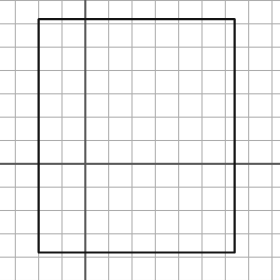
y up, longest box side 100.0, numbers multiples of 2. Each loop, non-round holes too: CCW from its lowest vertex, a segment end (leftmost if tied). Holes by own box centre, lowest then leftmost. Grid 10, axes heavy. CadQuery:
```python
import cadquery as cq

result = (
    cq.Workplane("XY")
    .moveTo(-20.0, -38.0)
    .lineTo(64.0, -38.0)
    .lineTo(64.0, 62.0)
    .lineTo(-20.0, 62.0)
    .close()
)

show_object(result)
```